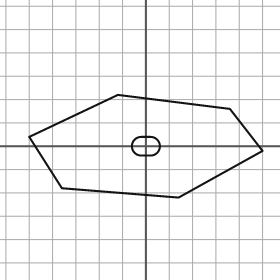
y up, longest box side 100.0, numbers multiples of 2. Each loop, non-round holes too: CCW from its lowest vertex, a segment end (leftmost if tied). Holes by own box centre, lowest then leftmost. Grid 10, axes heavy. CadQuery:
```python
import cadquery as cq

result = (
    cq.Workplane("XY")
    .moveTo(14.0, -22.0)
    .lineTo(50.0, -2.0)
    .lineTo(36.0, 16.0)
    .lineTo(-12.0, 22.0)
    .lineTo(-50.0, 4.0)
    .lineTo(-36.0, -18.0)
    .close()
    .moveTo(-2.0, -4.0)
    .lineTo(2.0, -4.0)
    .threePointArc((6.0, 0.0), (2.0, 4.0))
    .lineTo(-2.0, 4.0)
    .threePointArc((-6.0, 0.0), (-2.0, -4.0))
    .close()
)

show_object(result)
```